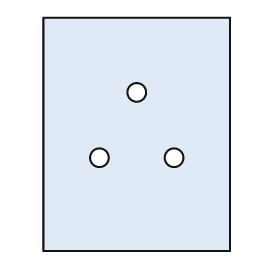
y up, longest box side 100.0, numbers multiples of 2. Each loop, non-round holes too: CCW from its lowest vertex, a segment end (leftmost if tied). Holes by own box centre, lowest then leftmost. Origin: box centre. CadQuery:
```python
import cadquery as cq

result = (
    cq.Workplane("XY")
    .moveTo(-40.0, -50.0)
    .lineTo(40.0, -50.0)
    .lineTo(40.0, 50.0)
    .lineTo(-40.0, 50.0)
    .close()
    .moveTo(-16.0, -10.0)
    .circle(4.0)
    .moveTo(16.0, -10.0)
    .circle(4.0)
    .moveTo(0.0, 18.0)
    .circle(4.0)
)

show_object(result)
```